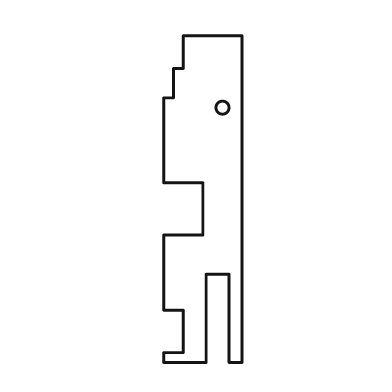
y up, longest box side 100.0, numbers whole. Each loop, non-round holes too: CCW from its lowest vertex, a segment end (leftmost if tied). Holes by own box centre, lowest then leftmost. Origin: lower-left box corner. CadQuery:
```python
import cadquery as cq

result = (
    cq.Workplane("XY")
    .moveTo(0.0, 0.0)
    .lineTo(13.0, 0.0)
    .lineTo(13.0, 27.0)
    .lineTo(20.0, 27.0)
    .lineTo(20.0, 0.0)
    .lineTo(24.0, 0.0)
    .lineTo(24.0, 100.0)
    .lineTo(6.0, 100.0)
    .lineTo(6.0, 90.0)
    .lineTo(3.0, 90.0)
    .lineTo(3.0, 81.0)
    .lineTo(0.0, 81.0)
    .lineTo(0.0, 55.0)
    .lineTo(12.0, 55.0)
    .lineTo(12.0, 39.0)
    .lineTo(0.0, 39.0)
    .lineTo(0.0, 16.0)
    .lineTo(6.0, 16.0)
    .lineTo(6.0, 3.0)
    .lineTo(0.0, 3.0)
    .close()
    .moveTo(18.0, 78.0)
    .circle(2.0)
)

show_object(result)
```